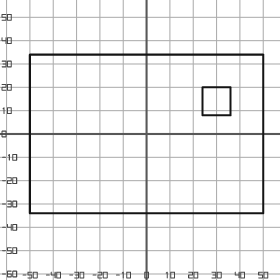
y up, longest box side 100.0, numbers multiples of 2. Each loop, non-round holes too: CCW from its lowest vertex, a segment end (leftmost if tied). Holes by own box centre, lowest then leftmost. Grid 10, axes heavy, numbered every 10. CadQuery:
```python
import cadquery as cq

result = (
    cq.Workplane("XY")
    .moveTo(-50.0, -34.0)
    .lineTo(50.0, -34.0)
    .lineTo(50.0, 34.0)
    .lineTo(-50.0, 34.0)
    .close()
    .moveTo(24.0, 8.0)
    .lineTo(36.0, 8.0)
    .lineTo(36.0, 20.0)
    .lineTo(24.0, 20.0)
    .close()
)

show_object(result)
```